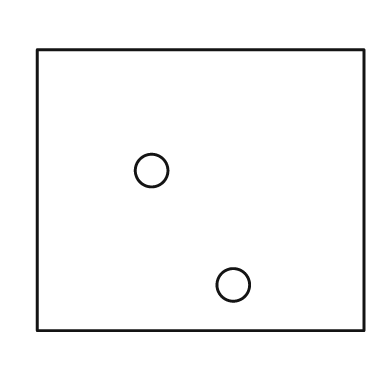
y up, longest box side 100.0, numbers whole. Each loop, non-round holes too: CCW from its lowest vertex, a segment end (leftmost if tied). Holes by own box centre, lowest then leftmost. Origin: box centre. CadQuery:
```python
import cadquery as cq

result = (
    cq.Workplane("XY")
    .moveTo(-50.0, -43.0)
    .lineTo(50.0, -43.0)
    .lineTo(50.0, 43.0)
    .lineTo(-50.0, 43.0)
    .close()
    .moveTo(10.0, -29.0)
    .circle(5.0)
    .moveTo(-15.0, 6.0)
    .circle(5.0)
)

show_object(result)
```